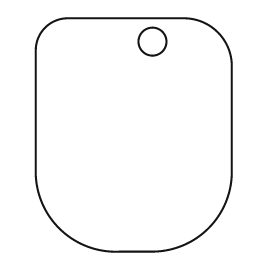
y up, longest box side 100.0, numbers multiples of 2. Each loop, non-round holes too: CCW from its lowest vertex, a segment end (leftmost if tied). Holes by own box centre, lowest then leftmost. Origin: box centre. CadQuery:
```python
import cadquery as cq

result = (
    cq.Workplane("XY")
    .moveTo(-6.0, -50.0)
    .lineTo(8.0, -50.0)
    .threePointArc((32.0, -40.0), (42.0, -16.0))
    .lineTo(42.0, 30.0)
    .threePointArc((36.0, 44.0), (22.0, 50.0))
    .lineTo(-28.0, 50.0)
    .threePointArc((-38.0, 46.0), (-42.0, 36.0))
    .lineTo(-42.0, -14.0)
    .threePointArc((-32.0, -40.0), (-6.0, -50.0))
    .close()
    .moveTo(8.0, 40.0)
    .circle(6.0)
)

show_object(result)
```